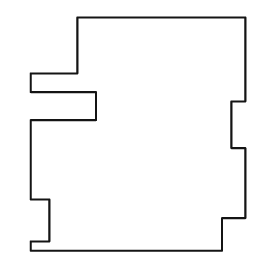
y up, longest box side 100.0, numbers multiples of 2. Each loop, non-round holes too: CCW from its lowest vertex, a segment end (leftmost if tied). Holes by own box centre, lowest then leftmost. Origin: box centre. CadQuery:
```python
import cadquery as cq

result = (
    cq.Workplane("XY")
    .moveTo(-46.0, -50.0)
    .lineTo(36.0, -50.0)
    .lineTo(36.0, -36.0)
    .lineTo(46.0, -36.0)
    .lineTo(46.0, -6.0)
    .lineTo(40.0, -6.0)
    .lineTo(40.0, 14.0)
    .lineTo(46.0, 14.0)
    .lineTo(46.0, 50.0)
    .lineTo(-26.0, 50.0)
    .lineTo(-26.0, 26.0)
    .lineTo(-46.0, 26.0)
    .lineTo(-46.0, 18.0)
    .lineTo(-18.0, 18.0)
    .lineTo(-18.0, 6.0)
    .lineTo(-46.0, 6.0)
    .lineTo(-46.0, -28.0)
    .lineTo(-38.0, -28.0)
    .lineTo(-38.0, -46.0)
    .lineTo(-46.0, -46.0)
    .close()
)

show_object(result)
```